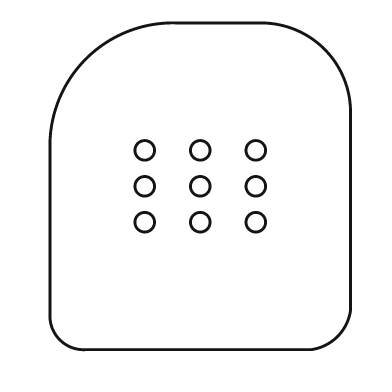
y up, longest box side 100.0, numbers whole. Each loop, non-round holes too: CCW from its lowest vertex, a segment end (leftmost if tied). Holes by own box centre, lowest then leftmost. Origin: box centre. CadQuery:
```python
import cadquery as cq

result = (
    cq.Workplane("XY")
    .moveTo(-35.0, -50.0)
    .lineTo(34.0, -50.0)
    .threePointArc((42.0, -46.0), (46.0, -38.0))
    .lineTo(46.0, 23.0)
    .threePointArc((38.0, 42.0), (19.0, 50.0))
    .lineTo(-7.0, 50.0)
    .threePointArc((-35.0, 39.0), (-46.0, 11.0))
    .lineTo(-46.0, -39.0)
    .threePointArc((-43.0, -47.0), (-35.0, -50.0))
    .close()
    .moveTo(-17.0, -11.0)
    .circle(3.0)
    .moveTo(0.0, -11.0)
    .circle(3.0)
    .moveTo(17.0, -11.0)
    .circle(3.0)
    .moveTo(-17.0, 0.0)
    .circle(3.0)
    .moveTo(0.0, 0.0)
    .circle(3.0)
    .moveTo(17.0, 0.0)
    .circle(3.0)
    .moveTo(-17.0, 11.0)
    .circle(3.0)
    .moveTo(0.0, 11.0)
    .circle(3.0)
    .moveTo(17.0, 11.0)
    .circle(3.0)
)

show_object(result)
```